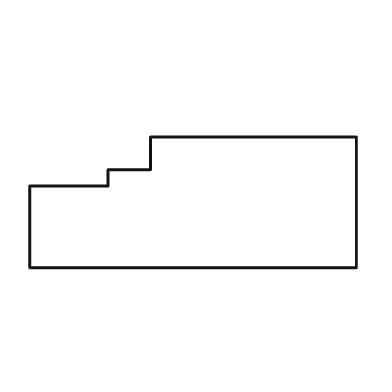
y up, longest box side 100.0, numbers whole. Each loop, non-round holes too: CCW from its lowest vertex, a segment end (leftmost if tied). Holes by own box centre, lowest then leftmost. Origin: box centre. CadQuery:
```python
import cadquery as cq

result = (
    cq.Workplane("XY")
    .moveTo(-50.0, -20.0)
    .lineTo(50.0, -20.0)
    .lineTo(50.0, 20.0)
    .lineTo(-13.0, 20.0)
    .lineTo(-13.0, 10.0)
    .lineTo(-26.0, 10.0)
    .lineTo(-26.0, 5.0)
    .lineTo(-50.0, 5.0)
    .close()
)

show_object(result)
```